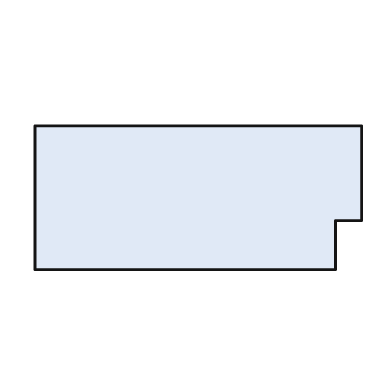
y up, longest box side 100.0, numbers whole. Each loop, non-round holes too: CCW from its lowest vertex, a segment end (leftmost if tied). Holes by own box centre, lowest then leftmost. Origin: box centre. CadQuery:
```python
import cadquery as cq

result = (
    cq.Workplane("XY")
    .moveTo(-50.0, -22.0)
    .lineTo(42.0, -22.0)
    .lineTo(42.0, -7.0)
    .lineTo(50.0, -7.0)
    .lineTo(50.0, 22.0)
    .lineTo(-50.0, 22.0)
    .close()
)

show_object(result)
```